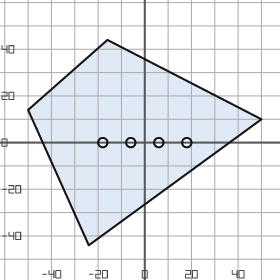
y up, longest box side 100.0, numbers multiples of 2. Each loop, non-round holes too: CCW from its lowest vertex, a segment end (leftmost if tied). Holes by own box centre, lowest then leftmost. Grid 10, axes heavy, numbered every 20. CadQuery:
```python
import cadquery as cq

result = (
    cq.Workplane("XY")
    .moveTo(-24.0, -44.0)
    .lineTo(50.0, 10.0)
    .lineTo(-16.0, 44.0)
    .lineTo(-50.0, 14.0)
    .close()
    .moveTo(-18.0, 0.0)
    .circle(2.0)
    .moveTo(-6.0, 0.0)
    .circle(2.0)
    .moveTo(6.0, 0.0)
    .circle(2.0)
    .moveTo(18.0, 0.0)
    .circle(2.0)
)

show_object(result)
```